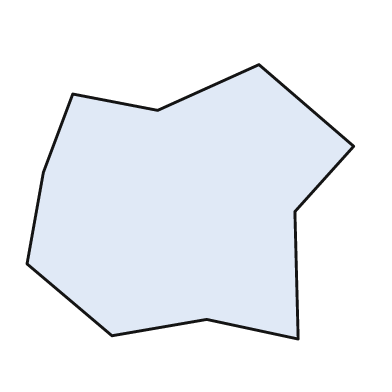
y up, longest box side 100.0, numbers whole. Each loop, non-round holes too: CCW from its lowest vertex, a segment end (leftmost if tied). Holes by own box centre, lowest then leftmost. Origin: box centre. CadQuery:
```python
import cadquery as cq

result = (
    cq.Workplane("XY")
    .moveTo(33.0, -42.0)
    .lineTo(32.0, -3.0)
    .lineTo(50.0, 17.0)
    .lineTo(21.0, 42.0)
    .lineTo(-10.0, 28.0)
    .lineTo(-36.0, 33.0)
    .lineTo(-45.0, 9.0)
    .lineTo(-50.0, -19.0)
    .lineTo(-24.0, -41.0)
    .lineTo(5.0, -36.0)
    .close()
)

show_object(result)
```